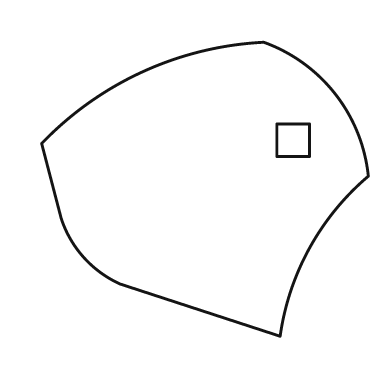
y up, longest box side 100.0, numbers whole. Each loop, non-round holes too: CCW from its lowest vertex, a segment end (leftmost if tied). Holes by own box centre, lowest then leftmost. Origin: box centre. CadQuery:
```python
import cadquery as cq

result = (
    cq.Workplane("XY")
    .moveTo(23.0, -45.0)
    .threePointArc((32.0, -18.0), (50.0, 4.0))
    .threePointArc((40.0, 29.0), (18.0, 45.0))
    .threePointArc((-19.0, 36.0), (-50.0, 14.0))
    .lineTo(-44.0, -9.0)
    .threePointArc((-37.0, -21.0), (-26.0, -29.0))
    .close()
    .moveTo(22.0, 10.0)
    .lineTo(32.0, 10.0)
    .lineTo(32.0, 20.0)
    .lineTo(22.0, 20.0)
    .close()
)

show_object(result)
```